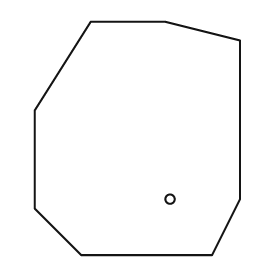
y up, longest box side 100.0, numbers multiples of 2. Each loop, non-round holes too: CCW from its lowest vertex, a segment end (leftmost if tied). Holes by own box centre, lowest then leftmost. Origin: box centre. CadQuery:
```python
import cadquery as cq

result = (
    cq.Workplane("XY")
    .moveTo(-24.0, -50.0)
    .lineTo(32.0, -50.0)
    .lineTo(44.0, -26.0)
    .lineTo(44.0, 42.0)
    .lineTo(12.0, 50.0)
    .lineTo(-20.0, 50.0)
    .lineTo(-44.0, 12.0)
    .lineTo(-44.0, -30.0)
    .close()
    .moveTo(14.0, -26.0)
    .circle(2.0)
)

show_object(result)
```